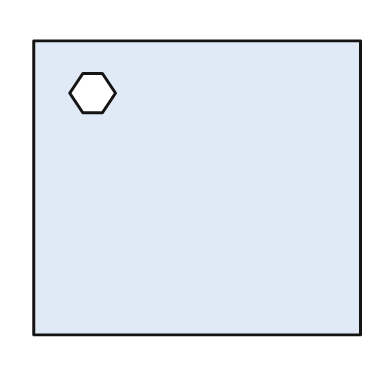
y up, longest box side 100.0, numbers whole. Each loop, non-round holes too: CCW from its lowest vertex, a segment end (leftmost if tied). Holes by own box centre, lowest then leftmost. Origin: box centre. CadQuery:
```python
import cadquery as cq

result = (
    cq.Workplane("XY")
    .moveTo(-50.0, -45.0)
    .lineTo(50.0, -45.0)
    .lineTo(50.0, 45.0)
    .lineTo(-50.0, 45.0)
    .close()
    .moveTo(-35.0, 23.0)
    .lineTo(-29.0, 23.0)
    .lineTo(-25.0, 29.0)
    .lineTo(-29.0, 35.0)
    .lineTo(-35.0, 35.0)
    .lineTo(-39.0, 29.0)
    .close()
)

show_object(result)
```